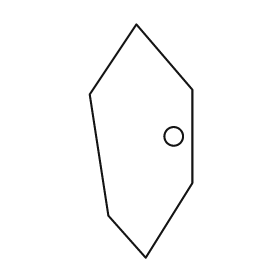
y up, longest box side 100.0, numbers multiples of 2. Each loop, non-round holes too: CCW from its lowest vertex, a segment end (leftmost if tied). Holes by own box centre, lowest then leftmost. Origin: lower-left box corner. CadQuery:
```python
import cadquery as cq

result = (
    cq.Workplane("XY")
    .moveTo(24.0, 0.0)
    .lineTo(44.0, 32.0)
    .lineTo(44.0, 72.0)
    .lineTo(20.0, 100.0)
    .lineTo(0.0, 70.0)
    .lineTo(8.0, 18.0)
    .close()
    .moveTo(36.0, 52.0)
    .circle(4.0)
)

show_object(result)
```